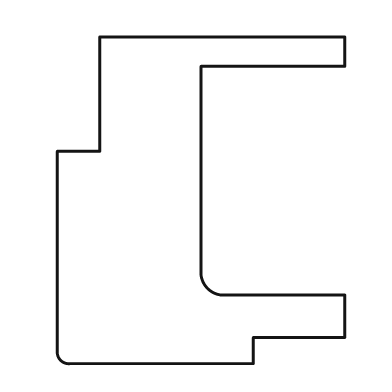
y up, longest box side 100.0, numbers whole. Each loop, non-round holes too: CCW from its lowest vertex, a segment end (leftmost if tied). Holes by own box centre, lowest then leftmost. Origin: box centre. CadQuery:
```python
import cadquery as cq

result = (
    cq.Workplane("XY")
    .moveTo(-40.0, -50.0)
    .lineTo(16.0, -50.0)
    .lineTo(16.0, -42.0)
    .lineTo(44.0, -42.0)
    .lineTo(44.0, -29.0)
    .lineTo(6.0, -29.0)
    .threePointArc((2.0, -27.0), (0.0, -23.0))
    .lineTo(0.0, 41.0)
    .lineTo(44.0, 41.0)
    .lineTo(44.0, 50.0)
    .lineTo(-31.0, 50.0)
    .lineTo(-31.0, 15.0)
    .lineTo(-44.0, 15.0)
    .lineTo(-44.0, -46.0)
    .threePointArc((-43.0, -49.0), (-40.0, -50.0))
    .close()
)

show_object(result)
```